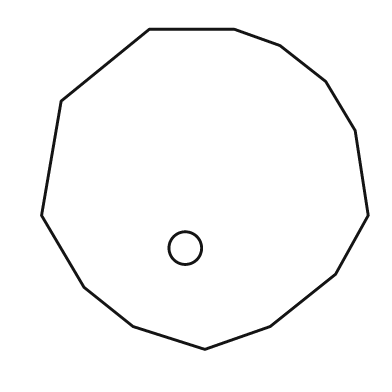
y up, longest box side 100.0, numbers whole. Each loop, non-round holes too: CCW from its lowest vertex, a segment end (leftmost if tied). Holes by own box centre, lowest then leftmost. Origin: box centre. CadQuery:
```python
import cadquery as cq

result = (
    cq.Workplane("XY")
    .moveTo(0.0, -49.0)
    .lineTo(20.0, -42.0)
    .lineTo(40.0, -26.0)
    .lineTo(50.0, -8.0)
    .lineTo(46.0, 18.0)
    .lineTo(37.0, 33.0)
    .lineTo(23.0, 44.0)
    .lineTo(9.0, 49.0)
    .lineTo(-17.0, 49.0)
    .lineTo(-44.0, 27.0)
    .lineTo(-50.0, -8.0)
    .lineTo(-37.0, -30.0)
    .lineTo(-22.0, -42.0)
    .close()
    .moveTo(-6.0, -18.0)
    .circle(5.0)
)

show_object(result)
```